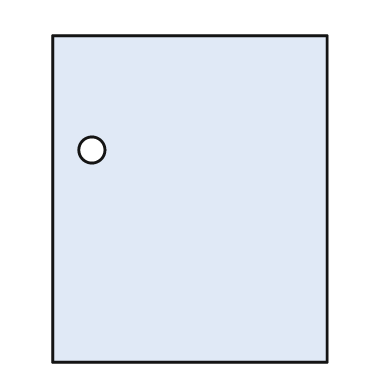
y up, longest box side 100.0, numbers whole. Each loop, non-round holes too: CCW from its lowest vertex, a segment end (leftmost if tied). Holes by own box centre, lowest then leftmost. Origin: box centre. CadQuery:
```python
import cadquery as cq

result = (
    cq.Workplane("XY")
    .moveTo(-42.0, -50.0)
    .lineTo(42.0, -50.0)
    .lineTo(42.0, 50.0)
    .lineTo(-42.0, 50.0)
    .close()
    .moveTo(-30.0, 15.0)
    .circle(4.0)
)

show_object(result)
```